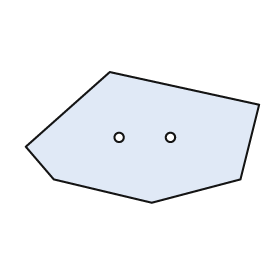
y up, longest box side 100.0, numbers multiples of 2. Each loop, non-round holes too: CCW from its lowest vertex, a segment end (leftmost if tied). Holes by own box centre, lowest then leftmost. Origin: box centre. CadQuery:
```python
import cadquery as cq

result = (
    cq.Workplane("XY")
    .moveTo(4.0, -28.0)
    .lineTo(42.0, -18.0)
    .lineTo(50.0, 14.0)
    .lineTo(-14.0, 28.0)
    .lineTo(-50.0, -4.0)
    .lineTo(-38.0, -18.0)
    .close()
    .moveTo(-10.0, 0.0)
    .circle(2.0)
    .moveTo(12.0, 0.0)
    .circle(2.0)
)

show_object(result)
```